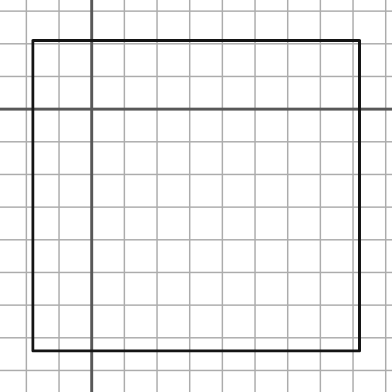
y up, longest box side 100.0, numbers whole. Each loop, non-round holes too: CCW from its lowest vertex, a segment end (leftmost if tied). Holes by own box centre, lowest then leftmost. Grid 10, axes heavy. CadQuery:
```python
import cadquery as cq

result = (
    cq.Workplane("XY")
    .moveTo(-18.0, -74.0)
    .lineTo(82.0, -74.0)
    .lineTo(82.0, 21.0)
    .lineTo(-18.0, 21.0)
    .close()
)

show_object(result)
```